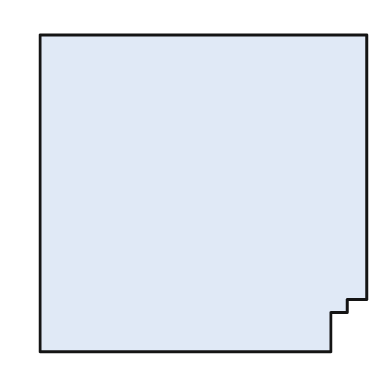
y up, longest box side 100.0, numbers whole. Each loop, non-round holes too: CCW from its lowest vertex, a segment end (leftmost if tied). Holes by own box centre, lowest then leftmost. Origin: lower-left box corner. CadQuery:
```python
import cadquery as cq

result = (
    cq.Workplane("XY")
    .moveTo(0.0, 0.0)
    .lineTo(89.0, 0.0)
    .lineTo(89.0, 12.0)
    .lineTo(94.0, 12.0)
    .lineTo(94.0, 16.0)
    .lineTo(100.0, 16.0)
    .lineTo(100.0, 97.0)
    .lineTo(0.0, 97.0)
    .close()
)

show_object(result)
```